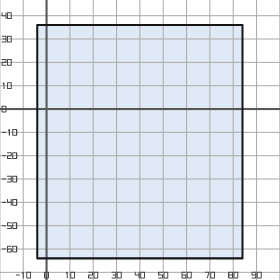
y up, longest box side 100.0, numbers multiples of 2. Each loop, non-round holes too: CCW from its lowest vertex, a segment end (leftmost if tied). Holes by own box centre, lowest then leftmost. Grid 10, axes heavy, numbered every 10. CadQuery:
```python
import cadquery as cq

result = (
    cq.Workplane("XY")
    .moveTo(-4.0, -64.0)
    .lineTo(84.0, -64.0)
    .lineTo(84.0, 36.0)
    .lineTo(-4.0, 36.0)
    .close()
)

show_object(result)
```